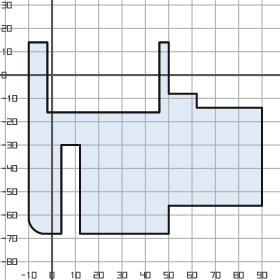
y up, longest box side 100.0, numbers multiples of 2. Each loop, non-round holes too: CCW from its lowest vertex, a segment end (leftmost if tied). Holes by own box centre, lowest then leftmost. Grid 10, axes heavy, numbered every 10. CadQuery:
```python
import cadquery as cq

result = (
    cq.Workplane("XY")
    .moveTo(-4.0, -68.0)
    .lineTo(4.0, -68.0)
    .lineTo(4.0, -30.0)
    .lineTo(12.0, -30.0)
    .lineTo(12.0, -68.0)
    .lineTo(50.0, -68.0)
    .lineTo(50.0, -56.0)
    .lineTo(90.0, -56.0)
    .lineTo(90.0, -14.0)
    .lineTo(62.0, -14.0)
    .lineTo(62.0, -8.0)
    .lineTo(50.0, -8.0)
    .lineTo(50.0, 14.0)
    .lineTo(46.0, 14.0)
    .lineTo(46.0, -16.0)
    .lineTo(-2.0, -16.0)
    .lineTo(-2.0, 14.0)
    .lineTo(-10.0, 14.0)
    .lineTo(-10.0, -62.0)
    .threePointArc((-8.0, -66.0), (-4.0, -68.0))
    .close()
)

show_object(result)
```